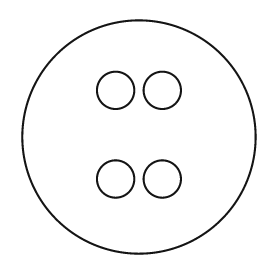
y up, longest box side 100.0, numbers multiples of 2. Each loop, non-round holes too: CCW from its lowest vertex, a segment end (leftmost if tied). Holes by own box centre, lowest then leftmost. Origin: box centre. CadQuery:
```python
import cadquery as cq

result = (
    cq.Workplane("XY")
    .moveTo(0.0, 0.0)
    .circle(50.0)
    .moveTo(-10.0, -18.0)
    .circle(8.0)
    .moveTo(10.0, -18.0)
    .circle(8.0)
    .moveTo(-10.0, 20.0)
    .circle(8.0)
    .moveTo(10.0, 20.0)
    .circle(8.0)
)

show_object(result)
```